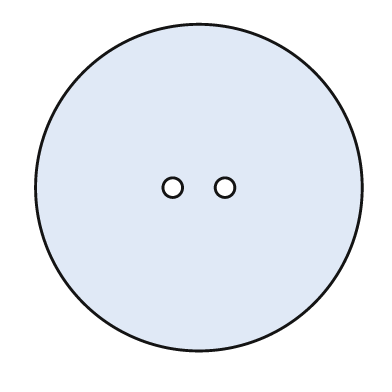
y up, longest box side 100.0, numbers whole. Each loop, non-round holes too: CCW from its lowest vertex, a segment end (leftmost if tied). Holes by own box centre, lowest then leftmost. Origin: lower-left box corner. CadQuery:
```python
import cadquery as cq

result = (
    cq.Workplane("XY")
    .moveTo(50.0, 50.0)
    .circle(50.0)
    .moveTo(42.0, 50.0)
    .circle(3.0)
    .moveTo(58.0, 50.0)
    .circle(3.0)
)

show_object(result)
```